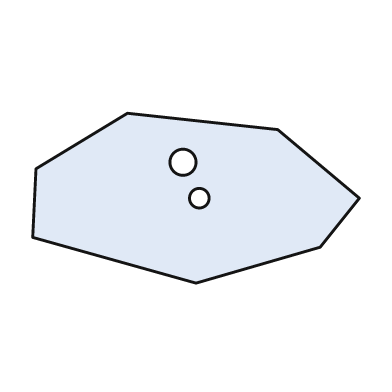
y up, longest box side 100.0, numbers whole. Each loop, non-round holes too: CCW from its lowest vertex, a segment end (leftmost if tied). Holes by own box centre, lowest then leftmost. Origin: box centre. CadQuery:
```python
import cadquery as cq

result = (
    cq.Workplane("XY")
    .moveTo(0.0, -26.0)
    .lineTo(38.0, -15.0)
    .lineTo(50.0, 0.0)
    .lineTo(25.0, 21.0)
    .lineTo(-21.0, 26.0)
    .lineTo(-49.0, 9.0)
    .lineTo(-50.0, -12.0)
    .close()
    .moveTo(1.0, 0.0)
    .circle(3.0)
    .moveTo(-4.0, 11.0)
    .circle(4.0)
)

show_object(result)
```